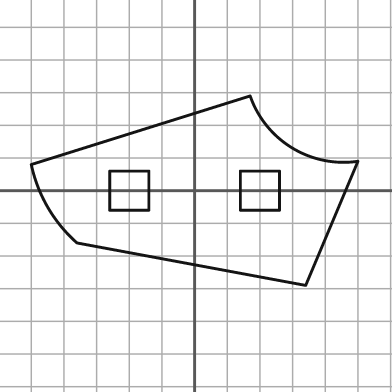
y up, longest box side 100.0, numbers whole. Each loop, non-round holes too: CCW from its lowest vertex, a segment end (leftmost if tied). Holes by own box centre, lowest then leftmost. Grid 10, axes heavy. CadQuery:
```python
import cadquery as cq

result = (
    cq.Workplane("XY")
    .moveTo(34.0, -29.0)
    .lineTo(50.0, 9.0)
    .threePointArc((30.0, 13.0), (17.0, 29.0))
    .lineTo(-50.0, 8.0)
    .threePointArc((-45.0, -5.0), (-36.0, -16.0))
    .close()
    .moveTo(-26.0, -6.0)
    .lineTo(-14.0, -6.0)
    .lineTo(-14.0, 6.0)
    .lineTo(-26.0, 6.0)
    .close()
    .moveTo(14.0, -6.0)
    .lineTo(26.0, -6.0)
    .lineTo(26.0, 6.0)
    .lineTo(14.0, 6.0)
    .close()
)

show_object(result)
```